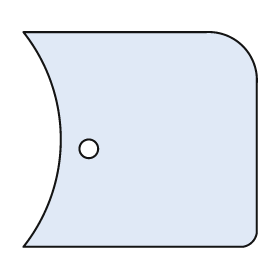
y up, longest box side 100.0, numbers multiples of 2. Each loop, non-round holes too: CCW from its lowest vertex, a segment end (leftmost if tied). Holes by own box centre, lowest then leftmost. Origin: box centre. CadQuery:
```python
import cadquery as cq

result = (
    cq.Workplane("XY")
    .moveTo(-50.0, -46.0)
    .lineTo(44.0, -46.0)
    .threePointArc((48.0, -44.0), (50.0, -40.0))
    .lineTo(50.0, 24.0)
    .threePointArc((44.0, 40.0), (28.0, 46.0))
    .lineTo(-50.0, 46.0)
    .threePointArc((-34.0, 0.0), (-50.0, -46.0))
    .close()
    .moveTo(-22.0, -4.0)
    .circle(4.0)
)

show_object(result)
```